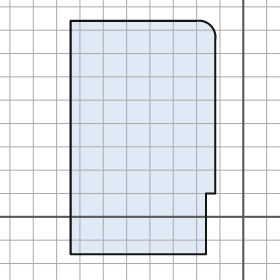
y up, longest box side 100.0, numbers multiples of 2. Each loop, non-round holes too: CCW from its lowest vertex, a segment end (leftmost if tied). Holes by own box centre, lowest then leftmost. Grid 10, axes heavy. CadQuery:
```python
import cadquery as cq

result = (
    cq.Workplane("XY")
    .moveTo(-74.0, -16.0)
    .lineTo(-16.0, -16.0)
    .lineTo(-16.0, 10.0)
    .lineTo(-12.0, 10.0)
    .lineTo(-12.0, 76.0)
    .threePointArc((-14.0, 82.0), (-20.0, 84.0))
    .lineTo(-74.0, 84.0)
    .close()
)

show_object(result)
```